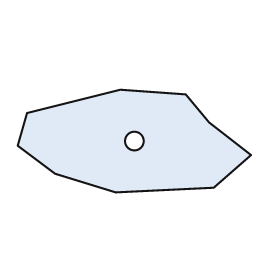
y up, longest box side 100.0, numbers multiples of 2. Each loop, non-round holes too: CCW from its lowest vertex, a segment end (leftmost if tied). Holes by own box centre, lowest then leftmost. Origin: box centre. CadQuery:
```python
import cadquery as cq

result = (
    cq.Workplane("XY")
    .moveTo(-8.0, -22.0)
    .lineTo(34.0, -20.0)
    .lineTo(50.0, -6.0)
    .lineTo(32.0, 8.0)
    .lineTo(22.0, 20.0)
    .lineTo(-6.0, 22.0)
    .lineTo(-46.0, 12.0)
    .lineTo(-50.0, -2.0)
    .lineTo(-34.0, -14.0)
    .close()
    .moveTo(0.0, 0.0)
    .circle(4.0)
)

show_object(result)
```